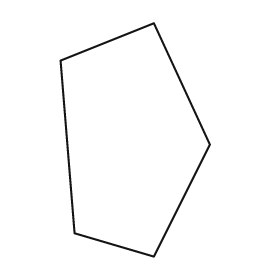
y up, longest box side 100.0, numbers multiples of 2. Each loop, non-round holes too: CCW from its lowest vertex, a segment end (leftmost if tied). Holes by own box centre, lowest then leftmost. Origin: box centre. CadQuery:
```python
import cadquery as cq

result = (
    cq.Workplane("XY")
    .moveTo(8.0, -50.0)
    .lineTo(32.0, -2.0)
    .lineTo(8.0, 50.0)
    .lineTo(-32.0, 34.0)
    .lineTo(-26.0, -40.0)
    .close()
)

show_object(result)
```